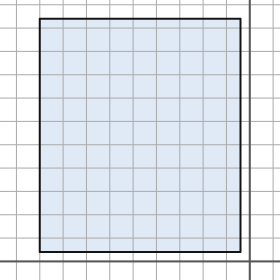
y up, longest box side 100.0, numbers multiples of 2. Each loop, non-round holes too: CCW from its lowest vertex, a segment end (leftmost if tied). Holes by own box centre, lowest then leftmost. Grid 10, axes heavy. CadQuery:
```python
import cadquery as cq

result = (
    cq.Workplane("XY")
    .moveTo(-90.0, 4.0)
    .lineTo(-4.0, 4.0)
    .lineTo(-4.0, 104.0)
    .lineTo(-90.0, 104.0)
    .close()
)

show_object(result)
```